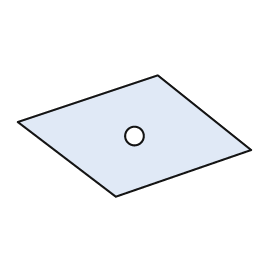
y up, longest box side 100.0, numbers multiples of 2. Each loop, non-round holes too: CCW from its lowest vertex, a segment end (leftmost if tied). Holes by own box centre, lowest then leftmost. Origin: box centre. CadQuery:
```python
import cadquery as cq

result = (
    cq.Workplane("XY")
    .moveTo(-8.0, -26.0)
    .lineTo(50.0, -6.0)
    .lineTo(10.0, 26.0)
    .lineTo(-50.0, 6.0)
    .close()
    .moveTo(0.0, 0.0)
    .circle(4.0)
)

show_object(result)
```